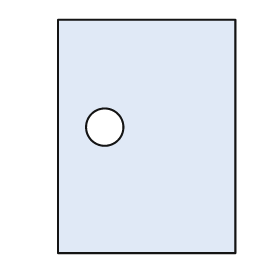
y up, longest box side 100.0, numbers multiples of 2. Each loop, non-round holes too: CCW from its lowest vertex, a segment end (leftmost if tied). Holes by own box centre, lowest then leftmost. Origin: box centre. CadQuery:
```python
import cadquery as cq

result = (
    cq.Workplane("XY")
    .moveTo(-38.0, -50.0)
    .lineTo(38.0, -50.0)
    .lineTo(38.0, 50.0)
    .lineTo(-38.0, 50.0)
    .close()
    .moveTo(-18.0, 4.0)
    .circle(8.0)
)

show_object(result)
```